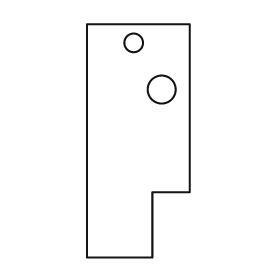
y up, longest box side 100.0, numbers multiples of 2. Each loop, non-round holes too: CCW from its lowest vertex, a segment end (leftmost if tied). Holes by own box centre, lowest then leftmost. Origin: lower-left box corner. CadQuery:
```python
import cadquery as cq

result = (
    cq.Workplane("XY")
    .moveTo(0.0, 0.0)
    .lineTo(28.0, 0.0)
    .lineTo(28.0, 28.0)
    .lineTo(44.0, 28.0)
    .lineTo(44.0, 100.0)
    .lineTo(0.0, 100.0)
    .close()
    .moveTo(32.0, 72.0)
    .circle(6.0)
    .moveTo(20.0, 92.0)
    .circle(4.0)
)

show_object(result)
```